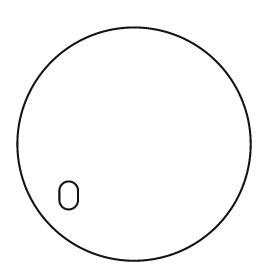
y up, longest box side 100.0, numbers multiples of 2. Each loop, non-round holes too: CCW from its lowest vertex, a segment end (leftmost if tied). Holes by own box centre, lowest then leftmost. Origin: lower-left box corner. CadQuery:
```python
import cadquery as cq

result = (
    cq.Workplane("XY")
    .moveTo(50.0, 50.0)
    .circle(50.0)
    .moveTo(18.0, 26.0)
    .threePointArc((22.0, 22.0), (26.0, 26.0))
    .lineTo(26.0, 30.0)
    .threePointArc((22.0, 34.0), (18.0, 30.0))
    .close()
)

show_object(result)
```